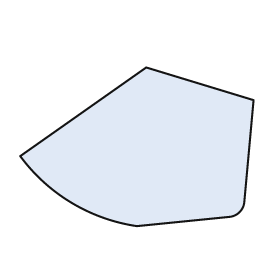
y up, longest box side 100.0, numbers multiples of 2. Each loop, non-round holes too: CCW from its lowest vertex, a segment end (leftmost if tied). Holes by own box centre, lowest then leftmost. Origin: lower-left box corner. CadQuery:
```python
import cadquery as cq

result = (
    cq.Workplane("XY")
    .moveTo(50.0, 0.0)
    .lineTo(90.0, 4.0)
    .threePointArc((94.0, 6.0), (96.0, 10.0))
    .lineTo(100.0, 54.0)
    .lineTo(54.0, 68.0)
    .lineTo(0.0, 30.0)
    .threePointArc((22.0, 10.0), (50.0, 0.0))
    .close()
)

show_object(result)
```